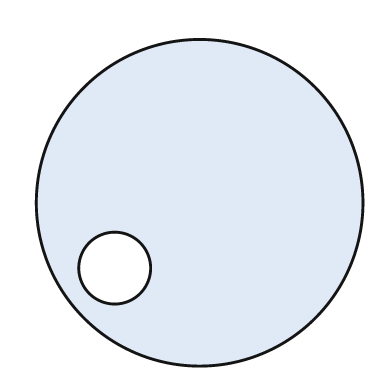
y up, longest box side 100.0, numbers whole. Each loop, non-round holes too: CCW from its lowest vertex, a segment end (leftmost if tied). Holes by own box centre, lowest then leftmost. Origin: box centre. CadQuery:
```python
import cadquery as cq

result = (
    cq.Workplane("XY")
    .moveTo(0.0, 0.0)
    .circle(50.0)
    .moveTo(-26.0, -20.0)
    .circle(11.0)
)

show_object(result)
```